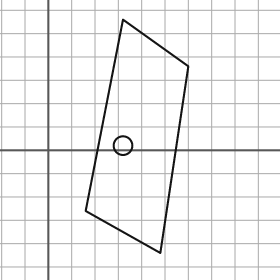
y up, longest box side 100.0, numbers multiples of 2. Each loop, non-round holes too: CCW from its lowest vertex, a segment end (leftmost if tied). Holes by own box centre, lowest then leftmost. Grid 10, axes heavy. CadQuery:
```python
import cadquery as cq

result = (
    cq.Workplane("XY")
    .moveTo(48.0, -44.0)
    .lineTo(60.0, 36.0)
    .lineTo(32.0, 56.0)
    .lineTo(16.0, -26.0)
    .close()
    .moveTo(32.0, 2.0)
    .circle(4.0)
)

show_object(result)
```